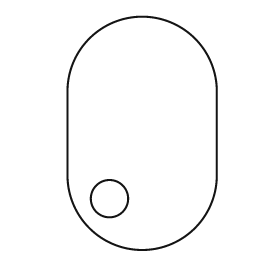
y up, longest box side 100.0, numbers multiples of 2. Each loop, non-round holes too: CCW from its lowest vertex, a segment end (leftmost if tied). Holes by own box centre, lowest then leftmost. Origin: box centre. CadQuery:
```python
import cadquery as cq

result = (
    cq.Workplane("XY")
    .moveTo(-32.0, -18.0)
    .threePointArc((0.0, -50.0), (32.0, -18.0))
    .lineTo(32.0, 18.0)
    .threePointArc((0.0, 50.0), (-32.0, 18.0))
    .close()
    .moveTo(-14.0, -28.0)
    .circle(8.0)
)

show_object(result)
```